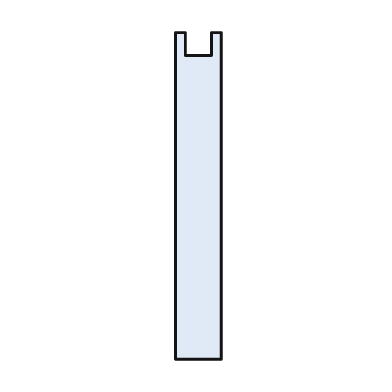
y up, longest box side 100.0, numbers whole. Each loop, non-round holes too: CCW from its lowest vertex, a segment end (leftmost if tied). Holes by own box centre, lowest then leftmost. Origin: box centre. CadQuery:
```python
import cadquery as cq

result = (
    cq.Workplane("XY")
    .moveTo(-7.0, -50.0)
    .lineTo(7.0, -50.0)
    .lineTo(7.0, 50.0)
    .lineTo(4.0, 50.0)
    .lineTo(4.0, 43.0)
    .lineTo(-4.0, 43.0)
    .lineTo(-4.0, 50.0)
    .lineTo(-7.0, 50.0)
    .close()
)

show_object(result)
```